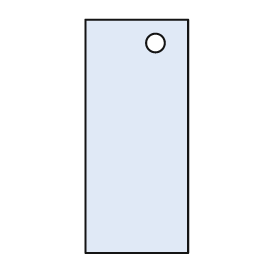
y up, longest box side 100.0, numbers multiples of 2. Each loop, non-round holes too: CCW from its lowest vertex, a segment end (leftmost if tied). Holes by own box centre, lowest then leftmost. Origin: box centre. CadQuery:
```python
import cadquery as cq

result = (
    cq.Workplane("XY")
    .moveTo(-22.0, -50.0)
    .lineTo(22.0, -50.0)
    .lineTo(22.0, 50.0)
    .lineTo(-22.0, 50.0)
    .close()
    .moveTo(8.0, 40.0)
    .circle(4.0)
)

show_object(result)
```